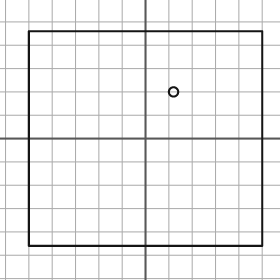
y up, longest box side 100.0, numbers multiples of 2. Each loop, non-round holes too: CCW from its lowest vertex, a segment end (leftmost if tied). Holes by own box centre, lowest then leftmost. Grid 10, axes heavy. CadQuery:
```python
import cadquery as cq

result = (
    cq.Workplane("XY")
    .moveTo(-50.0, -46.0)
    .lineTo(50.0, -46.0)
    .lineTo(50.0, 46.0)
    .lineTo(-50.0, 46.0)
    .close()
    .moveTo(12.0, 20.0)
    .circle(2.0)
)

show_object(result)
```